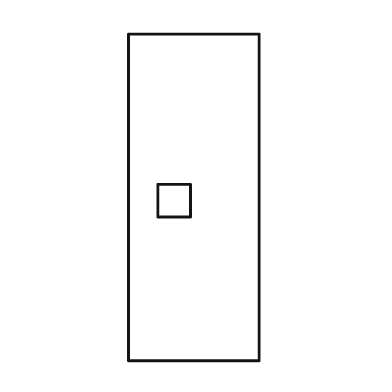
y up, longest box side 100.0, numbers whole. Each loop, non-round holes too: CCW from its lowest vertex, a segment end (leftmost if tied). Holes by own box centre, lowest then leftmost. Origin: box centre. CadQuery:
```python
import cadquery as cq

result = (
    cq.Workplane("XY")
    .moveTo(-20.0, -50.0)
    .lineTo(20.0, -50.0)
    .lineTo(20.0, 50.0)
    .lineTo(-20.0, 50.0)
    .close()
    .moveTo(-11.0, -6.0)
    .lineTo(-1.0, -6.0)
    .lineTo(-1.0, 4.0)
    .lineTo(-11.0, 4.0)
    .close()
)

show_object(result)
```